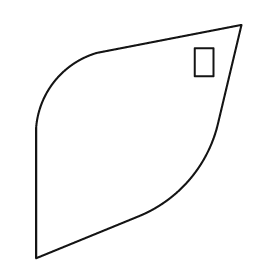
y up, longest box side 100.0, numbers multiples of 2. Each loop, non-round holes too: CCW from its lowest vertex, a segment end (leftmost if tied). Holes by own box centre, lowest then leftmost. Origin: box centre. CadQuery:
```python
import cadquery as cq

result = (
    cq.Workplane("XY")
    .moveTo(-44.0, -50.0)
    .lineTo(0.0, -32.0)
    .threePointArc((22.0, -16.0), (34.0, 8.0))
    .lineTo(44.0, 50.0)
    .lineTo(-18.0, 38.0)
    .threePointArc((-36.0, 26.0), (-44.0, 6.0))
    .close()
    .moveTo(24.0, 28.0)
    .lineTo(32.0, 28.0)
    .lineTo(32.0, 40.0)
    .lineTo(24.0, 40.0)
    .close()
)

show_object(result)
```